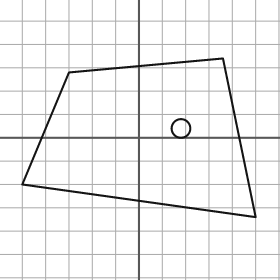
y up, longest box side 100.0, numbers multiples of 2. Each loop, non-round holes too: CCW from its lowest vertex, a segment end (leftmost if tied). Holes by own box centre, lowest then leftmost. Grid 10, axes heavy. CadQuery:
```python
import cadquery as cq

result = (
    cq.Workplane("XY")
    .moveTo(50.0, -34.0)
    .lineTo(36.0, 34.0)
    .lineTo(-30.0, 28.0)
    .lineTo(-50.0, -20.0)
    .close()
    .moveTo(18.0, 4.0)
    .circle(4.0)
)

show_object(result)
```